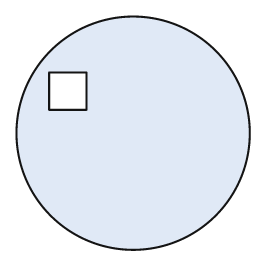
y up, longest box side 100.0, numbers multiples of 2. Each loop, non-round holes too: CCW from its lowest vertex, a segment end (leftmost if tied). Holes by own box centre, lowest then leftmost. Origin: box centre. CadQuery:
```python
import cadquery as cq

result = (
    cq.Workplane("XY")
    .moveTo(0.0, 0.0)
    .circle(50.0)
    .moveTo(-36.0, 10.0)
    .lineTo(-20.0, 10.0)
    .lineTo(-20.0, 26.0)
    .lineTo(-36.0, 26.0)
    .close()
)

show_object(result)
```